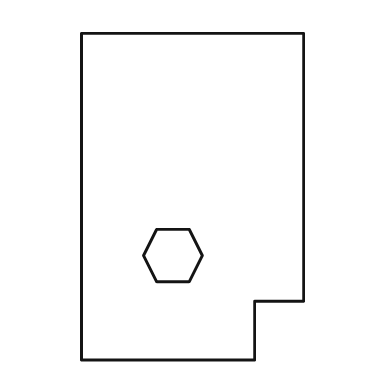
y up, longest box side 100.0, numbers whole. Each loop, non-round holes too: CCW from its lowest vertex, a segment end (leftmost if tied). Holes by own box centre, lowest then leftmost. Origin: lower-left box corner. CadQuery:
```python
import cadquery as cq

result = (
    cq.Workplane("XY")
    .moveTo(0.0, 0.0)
    .lineTo(53.0, 0.0)
    .lineTo(53.0, 18.0)
    .lineTo(68.0, 18.0)
    .lineTo(68.0, 100.0)
    .lineTo(0.0, 100.0)
    .close()
    .moveTo(23.0, 24.0)
    .lineTo(33.0, 24.0)
    .lineTo(37.0, 32.0)
    .lineTo(33.0, 40.0)
    .lineTo(23.0, 40.0)
    .lineTo(19.0, 32.0)
    .close()
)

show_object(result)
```